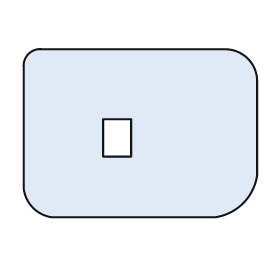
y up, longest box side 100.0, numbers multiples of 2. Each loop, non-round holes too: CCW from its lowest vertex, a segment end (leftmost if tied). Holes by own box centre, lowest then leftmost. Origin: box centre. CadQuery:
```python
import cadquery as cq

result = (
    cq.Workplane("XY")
    .moveTo(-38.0, -36.0)
    .lineTo(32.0, -36.0)
    .threePointArc((44.0, -30.0), (50.0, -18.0))
    .lineTo(50.0, 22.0)
    .threePointArc((46.0, 32.0), (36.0, 36.0))
    .lineTo(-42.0, 36.0)
    .threePointArc((-48.0, 34.0), (-50.0, 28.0))
    .lineTo(-50.0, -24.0)
    .threePointArc((-46.0, -32.0), (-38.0, -36.0))
    .close()
    .moveTo(-16.0, -10.0)
    .lineTo(-4.0, -10.0)
    .lineTo(-4.0, 6.0)
    .lineTo(-16.0, 6.0)
    .close()
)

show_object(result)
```